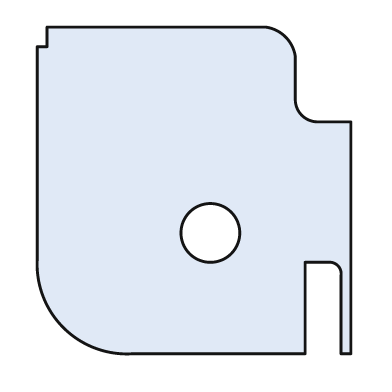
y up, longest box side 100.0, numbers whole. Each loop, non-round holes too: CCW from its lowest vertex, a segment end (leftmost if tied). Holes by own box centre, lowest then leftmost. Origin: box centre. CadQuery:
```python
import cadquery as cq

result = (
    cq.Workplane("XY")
    .moveTo(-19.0, -50.0)
    .lineTo(34.0, -50.0)
    .lineTo(34.0, -22.0)
    .lineTo(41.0, -22.0)
    .threePointArc((44.0, -23.0), (45.0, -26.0))
    .lineTo(45.0, -50.0)
    .lineTo(48.0, -50.0)
    .lineTo(48.0, 21.0)
    .lineTo(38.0, 21.0)
    .threePointArc((33.0, 23.0), (31.0, 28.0))
    .lineTo(31.0, 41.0)
    .threePointArc((28.0, 47.0), (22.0, 50.0))
    .lineTo(-45.0, 50.0)
    .lineTo(-45.0, 44.0)
    .lineTo(-48.0, 44.0)
    .lineTo(-48.0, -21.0)
    .threePointArc((-40.0, -42.0), (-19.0, -50.0))
    .close()
    .moveTo(5.0, -13.0)
    .circle(9.0)
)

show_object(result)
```